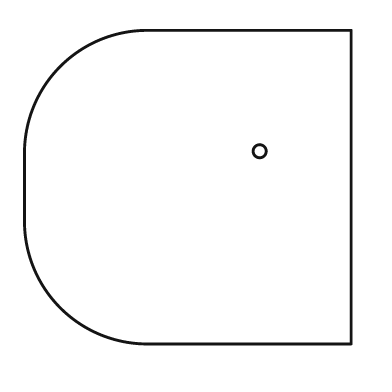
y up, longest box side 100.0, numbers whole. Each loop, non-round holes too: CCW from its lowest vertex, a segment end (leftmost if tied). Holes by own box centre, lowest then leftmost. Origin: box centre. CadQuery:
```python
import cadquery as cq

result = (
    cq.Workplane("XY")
    .moveTo(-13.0, -48.0)
    .lineTo(50.0, -48.0)
    .lineTo(50.0, 48.0)
    .lineTo(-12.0, 48.0)
    .threePointArc((-39.0, 37.0), (-50.0, 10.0))
    .lineTo(-50.0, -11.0)
    .threePointArc((-39.0, -37.0), (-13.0, -48.0))
    .close()
    .moveTo(22.0, 11.0)
    .circle(2.0)
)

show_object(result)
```